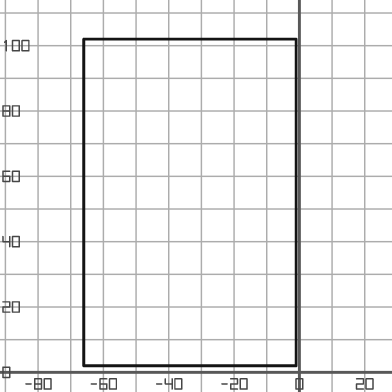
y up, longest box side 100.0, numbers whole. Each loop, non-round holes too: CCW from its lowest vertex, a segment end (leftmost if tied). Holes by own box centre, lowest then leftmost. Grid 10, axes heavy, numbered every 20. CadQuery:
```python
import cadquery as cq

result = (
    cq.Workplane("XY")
    .moveTo(-66.0, 2.0)
    .lineTo(-1.0, 2.0)
    .lineTo(-1.0, 102.0)
    .lineTo(-66.0, 102.0)
    .close()
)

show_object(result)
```